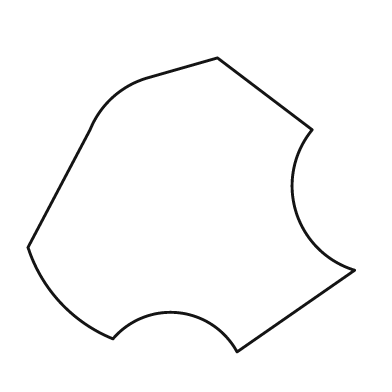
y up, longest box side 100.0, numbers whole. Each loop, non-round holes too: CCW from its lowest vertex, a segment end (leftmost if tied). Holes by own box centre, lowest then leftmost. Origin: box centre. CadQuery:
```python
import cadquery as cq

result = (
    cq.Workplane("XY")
    .moveTo(14.0, -45.0)
    .lineTo(50.0, -20.0)
    .threePointArc((32.0, -2.0), (37.0, 23.0))
    .lineTo(8.0, 45.0)
    .lineTo(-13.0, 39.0)
    .threePointArc((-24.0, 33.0), (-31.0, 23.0))
    .lineTo(-50.0, -13.0)
    .threePointArc((-40.0, -30.0), (-24.0, -41.0))
    .threePointArc((-4.0, -33.0), (14.0, -45.0))
    .close()
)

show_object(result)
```